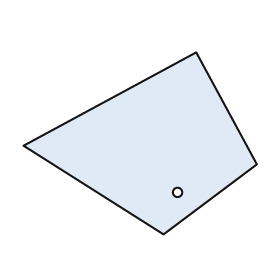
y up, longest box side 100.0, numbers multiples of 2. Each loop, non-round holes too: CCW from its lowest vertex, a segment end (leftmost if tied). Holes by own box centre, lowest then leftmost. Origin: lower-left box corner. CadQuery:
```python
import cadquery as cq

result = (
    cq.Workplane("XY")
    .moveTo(60.0, 0.0)
    .lineTo(100.0, 30.0)
    .lineTo(74.0, 78.0)
    .lineTo(0.0, 38.0)
    .close()
    .moveTo(66.0, 18.0)
    .circle(2.0)
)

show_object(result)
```